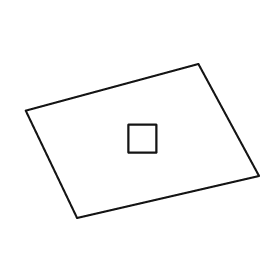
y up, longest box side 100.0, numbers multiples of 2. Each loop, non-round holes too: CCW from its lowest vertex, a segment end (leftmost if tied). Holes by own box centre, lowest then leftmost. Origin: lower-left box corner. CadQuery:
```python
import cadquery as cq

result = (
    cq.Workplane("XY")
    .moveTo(22.0, 0.0)
    .lineTo(100.0, 18.0)
    .lineTo(74.0, 66.0)
    .lineTo(0.0, 46.0)
    .close()
    .moveTo(44.0, 28.0)
    .lineTo(56.0, 28.0)
    .lineTo(56.0, 40.0)
    .lineTo(44.0, 40.0)
    .close()
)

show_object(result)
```